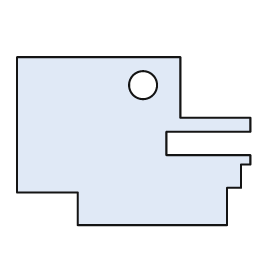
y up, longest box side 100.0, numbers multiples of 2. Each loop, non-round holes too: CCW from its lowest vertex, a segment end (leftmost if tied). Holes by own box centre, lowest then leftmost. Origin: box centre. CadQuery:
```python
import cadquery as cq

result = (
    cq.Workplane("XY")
    .moveTo(-24.0, -36.0)
    .lineTo(40.0, -36.0)
    .lineTo(40.0, -20.0)
    .lineTo(46.0, -20.0)
    .lineTo(46.0, -10.0)
    .lineTo(50.0, -10.0)
    .lineTo(50.0, -6.0)
    .lineTo(14.0, -6.0)
    .lineTo(14.0, 4.0)
    .lineTo(50.0, 4.0)
    .lineTo(50.0, 10.0)
    .lineTo(20.0, 10.0)
    .lineTo(20.0, 36.0)
    .lineTo(-50.0, 36.0)
    .lineTo(-50.0, -22.0)
    .lineTo(-24.0, -22.0)
    .close()
    .moveTo(4.0, 24.0)
    .circle(6.0)
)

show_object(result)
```